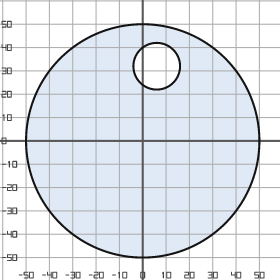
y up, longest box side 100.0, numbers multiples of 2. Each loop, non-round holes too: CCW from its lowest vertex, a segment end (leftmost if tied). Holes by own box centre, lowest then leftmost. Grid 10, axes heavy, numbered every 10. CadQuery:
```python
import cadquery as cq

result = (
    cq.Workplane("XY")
    .moveTo(0.0, 0.0)
    .circle(50.0)
    .moveTo(6.0, 32.0)
    .circle(10.0)
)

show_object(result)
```